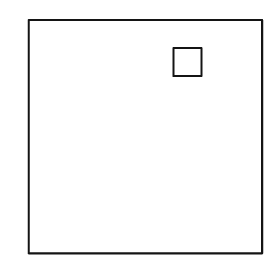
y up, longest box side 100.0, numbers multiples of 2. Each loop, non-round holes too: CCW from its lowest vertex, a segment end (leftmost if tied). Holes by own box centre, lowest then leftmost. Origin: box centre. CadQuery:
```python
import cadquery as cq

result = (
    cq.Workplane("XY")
    .moveTo(-50.0, -50.0)
    .lineTo(50.0, -50.0)
    .lineTo(50.0, 50.0)
    .lineTo(-50.0, 50.0)
    .close()
    .moveTo(12.0, 26.0)
    .lineTo(24.0, 26.0)
    .lineTo(24.0, 38.0)
    .lineTo(12.0, 38.0)
    .close()
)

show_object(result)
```